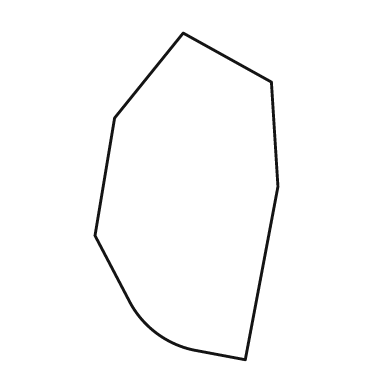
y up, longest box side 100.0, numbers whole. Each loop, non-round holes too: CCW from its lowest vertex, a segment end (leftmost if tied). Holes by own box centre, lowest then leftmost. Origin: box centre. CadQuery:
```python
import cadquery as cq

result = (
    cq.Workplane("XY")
    .moveTo(18.0, -50.0)
    .lineTo(28.0, 3.0)
    .lineTo(26.0, 35.0)
    .lineTo(-1.0, 50.0)
    .lineTo(-22.0, 24.0)
    .lineTo(-28.0, -12.0)
    .lineTo(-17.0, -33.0)
    .threePointArc((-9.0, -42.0), (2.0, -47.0))
    .close()
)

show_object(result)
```